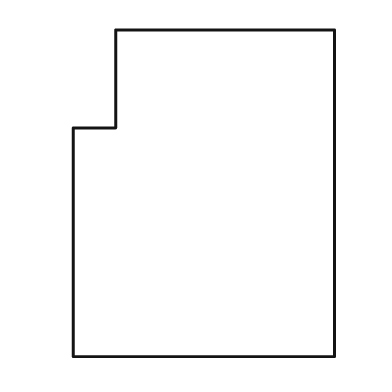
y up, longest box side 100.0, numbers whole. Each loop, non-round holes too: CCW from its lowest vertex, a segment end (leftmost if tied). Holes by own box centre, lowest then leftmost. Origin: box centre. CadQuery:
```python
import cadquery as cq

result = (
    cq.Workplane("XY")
    .moveTo(-40.0, -50.0)
    .lineTo(40.0, -50.0)
    .lineTo(40.0, 50.0)
    .lineTo(-27.0, 50.0)
    .lineTo(-27.0, 20.0)
    .lineTo(-40.0, 20.0)
    .close()
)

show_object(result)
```